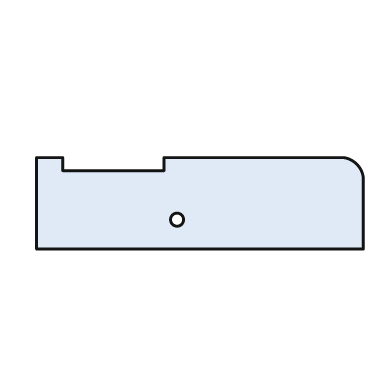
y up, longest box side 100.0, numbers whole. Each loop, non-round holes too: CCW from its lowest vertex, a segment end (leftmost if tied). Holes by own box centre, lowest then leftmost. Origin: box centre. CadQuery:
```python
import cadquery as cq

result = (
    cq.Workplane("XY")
    .moveTo(-50.0, -14.0)
    .lineTo(50.0, -14.0)
    .lineTo(50.0, 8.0)
    .threePointArc((48.0, 12.0), (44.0, 14.0))
    .lineTo(-11.0, 14.0)
    .lineTo(-11.0, 10.0)
    .lineTo(-42.0, 10.0)
    .lineTo(-42.0, 14.0)
    .lineTo(-50.0, 14.0)
    .close()
    .moveTo(-7.0, -5.0)
    .circle(2.0)
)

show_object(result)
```